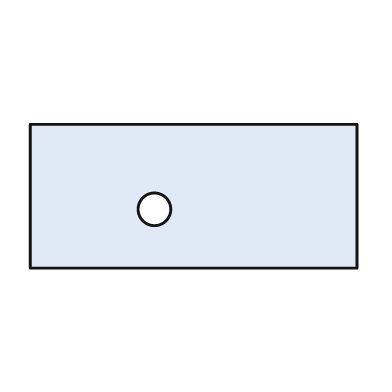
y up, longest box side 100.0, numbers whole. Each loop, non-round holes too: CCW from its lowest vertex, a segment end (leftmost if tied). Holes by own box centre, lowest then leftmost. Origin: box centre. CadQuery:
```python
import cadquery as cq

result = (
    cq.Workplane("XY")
    .moveTo(-50.0, -22.0)
    .lineTo(50.0, -22.0)
    .lineTo(50.0, 22.0)
    .lineTo(-50.0, 22.0)
    .close()
    .moveTo(-12.0, -4.0)
    .circle(5.0)
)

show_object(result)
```